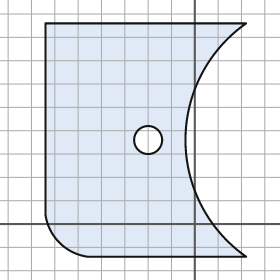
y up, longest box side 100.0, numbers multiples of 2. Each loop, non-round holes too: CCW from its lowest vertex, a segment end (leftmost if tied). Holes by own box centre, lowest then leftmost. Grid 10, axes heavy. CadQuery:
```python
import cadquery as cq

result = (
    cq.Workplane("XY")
    .moveTo(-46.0, -14.0)
    .lineTo(22.0, -14.0)
    .threePointArc((-4.0, 36.0), (22.0, 86.0))
    .lineTo(-64.0, 86.0)
    .lineTo(-64.0, 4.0)
    .threePointArc((-58.0, -8.0), (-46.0, -14.0))
    .close()
    .moveTo(-20.0, 36.0)
    .circle(6.0)
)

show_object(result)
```